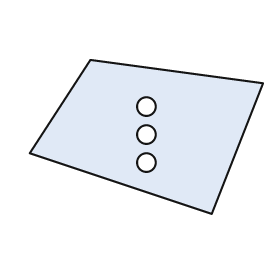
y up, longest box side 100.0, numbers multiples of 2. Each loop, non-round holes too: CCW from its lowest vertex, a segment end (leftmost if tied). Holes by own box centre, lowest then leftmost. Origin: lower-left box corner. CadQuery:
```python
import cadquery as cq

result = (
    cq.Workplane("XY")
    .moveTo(78.0, 0.0)
    .lineTo(100.0, 56.0)
    .lineTo(26.0, 66.0)
    .lineTo(0.0, 26.0)
    .close()
    .moveTo(50.0, 22.0)
    .circle(4.0)
    .moveTo(50.0, 34.0)
    .circle(4.0)
    .moveTo(50.0, 46.0)
    .circle(4.0)
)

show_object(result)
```